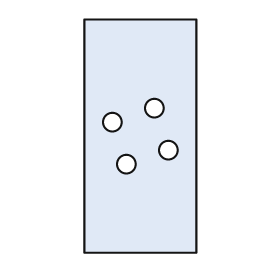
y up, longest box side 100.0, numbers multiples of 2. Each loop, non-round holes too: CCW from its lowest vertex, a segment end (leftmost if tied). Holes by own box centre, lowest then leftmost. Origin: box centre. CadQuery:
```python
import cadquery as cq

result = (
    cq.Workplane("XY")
    .moveTo(-24.0, -50.0)
    .lineTo(24.0, -50.0)
    .lineTo(24.0, 50.0)
    .lineTo(-24.0, 50.0)
    .close()
    .moveTo(-6.0, -12.0)
    .circle(4.0)
    .moveTo(12.0, -6.0)
    .circle(4.0)
    .moveTo(-12.0, 6.0)
    .circle(4.0)
    .moveTo(6.0, 12.0)
    .circle(4.0)
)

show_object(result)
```